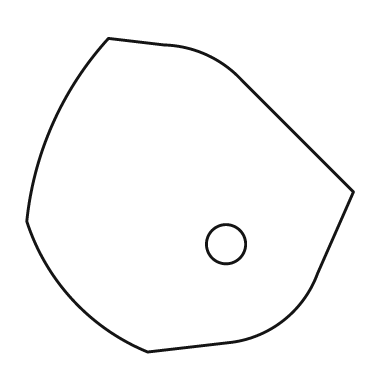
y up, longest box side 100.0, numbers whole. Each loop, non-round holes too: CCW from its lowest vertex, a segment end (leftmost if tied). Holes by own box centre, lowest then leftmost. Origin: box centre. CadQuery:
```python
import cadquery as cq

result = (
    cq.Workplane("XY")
    .moveTo(-13.0, -48.0)
    .lineTo(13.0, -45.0)
    .threePointArc((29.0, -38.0), (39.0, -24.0))
    .lineTo(50.0, 1.0)
    .lineTo(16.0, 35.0)
    .threePointArc((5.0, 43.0), (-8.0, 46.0))
    .lineTo(-25.0, 48.0)
    .threePointArc((-42.0, 22.0), (-50.0, -8.0))
    .threePointArc((-36.0, -32.0), (-13.0, -48.0))
    .close()
    .moveTo(11.0, -15.0)
    .circle(6.0)
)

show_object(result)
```